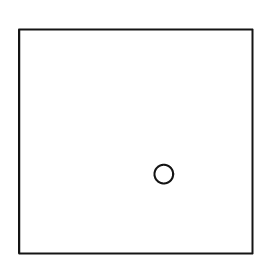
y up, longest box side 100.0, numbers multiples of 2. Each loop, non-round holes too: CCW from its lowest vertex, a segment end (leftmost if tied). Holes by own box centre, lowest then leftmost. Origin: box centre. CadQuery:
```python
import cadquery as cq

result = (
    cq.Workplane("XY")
    .moveTo(-50.0, -48.0)
    .lineTo(50.0, -48.0)
    .lineTo(50.0, 48.0)
    .lineTo(-50.0, 48.0)
    .close()
    .moveTo(12.0, -14.0)
    .circle(4.0)
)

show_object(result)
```